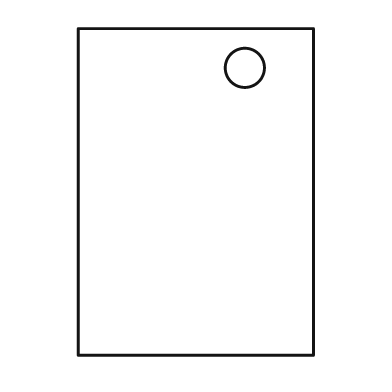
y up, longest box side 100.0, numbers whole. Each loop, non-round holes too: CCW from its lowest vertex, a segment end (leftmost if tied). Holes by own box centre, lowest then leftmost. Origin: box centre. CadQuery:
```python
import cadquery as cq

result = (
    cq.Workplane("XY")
    .moveTo(-36.0, -50.0)
    .lineTo(36.0, -50.0)
    .lineTo(36.0, 50.0)
    .lineTo(-36.0, 50.0)
    .close()
    .moveTo(15.0, 38.0)
    .circle(6.0)
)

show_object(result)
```